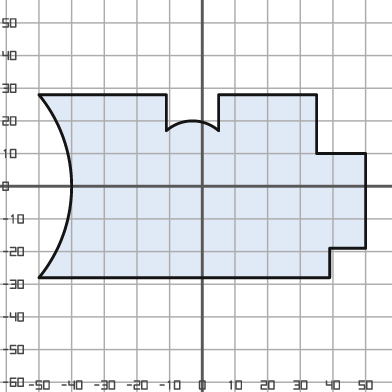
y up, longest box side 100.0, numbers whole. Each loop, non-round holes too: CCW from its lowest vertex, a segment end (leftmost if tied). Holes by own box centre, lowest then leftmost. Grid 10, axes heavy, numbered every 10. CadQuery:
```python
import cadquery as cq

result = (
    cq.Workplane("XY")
    .moveTo(-50.0, -28.0)
    .lineTo(39.0, -28.0)
    .lineTo(39.0, -19.0)
    .lineTo(50.0, -19.0)
    .lineTo(50.0, 10.0)
    .lineTo(35.0, 10.0)
    .lineTo(35.0, 28.0)
    .lineTo(5.0, 28.0)
    .lineTo(5.0, 17.0)
    .threePointArc((-3.0, 20.0), (-11.0, 17.0))
    .lineTo(-11.0, 28.0)
    .lineTo(-50.0, 28.0)
    .threePointArc((-40.0, 0.0), (-50.0, -28.0))
    .close()
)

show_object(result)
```